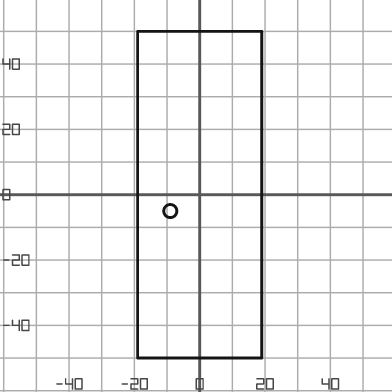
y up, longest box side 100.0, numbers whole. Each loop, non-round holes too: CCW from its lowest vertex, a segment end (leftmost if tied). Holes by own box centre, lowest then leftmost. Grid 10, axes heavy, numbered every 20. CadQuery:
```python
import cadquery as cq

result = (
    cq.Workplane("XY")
    .moveTo(-19.0, -50.0)
    .lineTo(19.0, -50.0)
    .lineTo(19.0, 50.0)
    .lineTo(-19.0, 50.0)
    .close()
    .moveTo(-9.0, -5.0)
    .circle(2.0)
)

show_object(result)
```